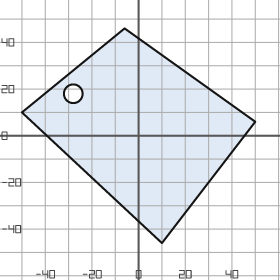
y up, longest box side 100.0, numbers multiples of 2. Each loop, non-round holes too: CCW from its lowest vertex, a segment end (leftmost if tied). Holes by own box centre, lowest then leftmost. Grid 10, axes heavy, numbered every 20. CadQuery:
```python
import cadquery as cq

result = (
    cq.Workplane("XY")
    .moveTo(10.0, -46.0)
    .lineTo(50.0, 6.0)
    .lineTo(-6.0, 46.0)
    .lineTo(-50.0, 10.0)
    .close()
    .moveTo(-28.0, 18.0)
    .circle(4.0)
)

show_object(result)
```